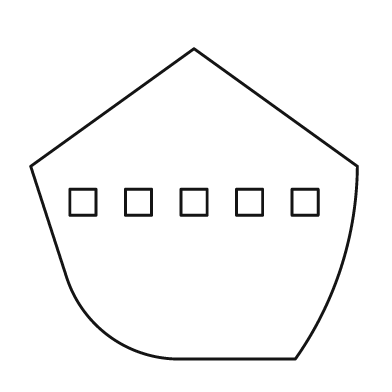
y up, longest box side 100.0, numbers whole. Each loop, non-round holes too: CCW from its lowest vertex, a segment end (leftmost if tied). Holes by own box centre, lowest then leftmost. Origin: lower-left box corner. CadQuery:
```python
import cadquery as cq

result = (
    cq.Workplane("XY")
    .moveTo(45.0, 0.0)
    .lineTo(81.0, 0.0)
    .threePointArc((95.0, 28.0), (100.0, 59.0))
    .lineTo(50.0, 95.0)
    .lineTo(0.0, 59.0)
    .lineTo(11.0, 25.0)
    .threePointArc((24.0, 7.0), (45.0, 0.0))
    .close()
    .moveTo(12.0, 44.0)
    .lineTo(20.0, 44.0)
    .lineTo(20.0, 52.0)
    .lineTo(12.0, 52.0)
    .close()
    .moveTo(29.0, 44.0)
    .lineTo(37.0, 44.0)
    .lineTo(37.0, 52.0)
    .lineTo(29.0, 52.0)
    .close()
    .moveTo(46.0, 44.0)
    .lineTo(54.0, 44.0)
    .lineTo(54.0, 52.0)
    .lineTo(46.0, 52.0)
    .close()
    .moveTo(63.0, 44.0)
    .lineTo(71.0, 44.0)
    .lineTo(71.0, 52.0)
    .lineTo(63.0, 52.0)
    .close()
    .moveTo(80.0, 44.0)
    .lineTo(88.0, 44.0)
    .lineTo(88.0, 52.0)
    .lineTo(80.0, 52.0)
    .close()
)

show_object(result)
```